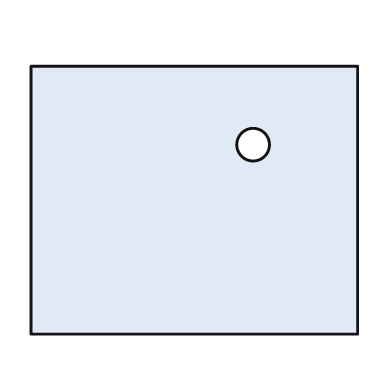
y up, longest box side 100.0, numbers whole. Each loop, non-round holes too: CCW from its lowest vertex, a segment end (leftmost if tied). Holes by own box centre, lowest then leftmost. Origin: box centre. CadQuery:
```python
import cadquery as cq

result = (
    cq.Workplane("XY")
    .moveTo(-50.0, -41.0)
    .lineTo(50.0, -41.0)
    .lineTo(50.0, 41.0)
    .lineTo(-50.0, 41.0)
    .close()
    .moveTo(18.0, 17.0)
    .circle(5.0)
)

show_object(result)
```